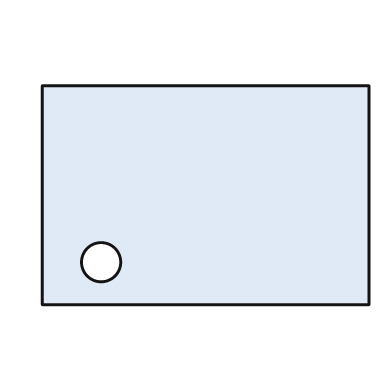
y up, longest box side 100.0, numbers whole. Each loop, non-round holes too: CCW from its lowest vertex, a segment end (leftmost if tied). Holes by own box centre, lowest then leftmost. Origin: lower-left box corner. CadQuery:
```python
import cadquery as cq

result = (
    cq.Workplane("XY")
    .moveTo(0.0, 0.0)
    .lineTo(100.0, 0.0)
    .lineTo(100.0, 67.0)
    .lineTo(0.0, 67.0)
    .close()
    .moveTo(18.0, 13.0)
    .circle(6.0)
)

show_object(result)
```